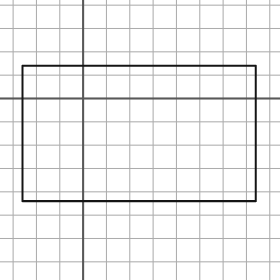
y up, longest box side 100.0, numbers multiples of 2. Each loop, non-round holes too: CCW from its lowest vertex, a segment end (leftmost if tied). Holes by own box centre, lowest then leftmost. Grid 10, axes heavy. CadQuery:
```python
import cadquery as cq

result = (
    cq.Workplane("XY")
    .moveTo(-26.0, -44.0)
    .lineTo(74.0, -44.0)
    .lineTo(74.0, 14.0)
    .lineTo(-26.0, 14.0)
    .close()
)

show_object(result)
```